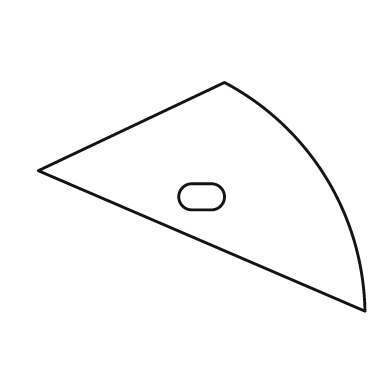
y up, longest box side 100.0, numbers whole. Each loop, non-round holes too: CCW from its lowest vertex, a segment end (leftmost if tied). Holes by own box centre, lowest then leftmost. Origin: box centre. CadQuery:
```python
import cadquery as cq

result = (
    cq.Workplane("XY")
    .moveTo(50.0, -35.0)
    .threePointArc((38.0, 6.0), (7.0, 35.0))
    .lineTo(-50.0, 8.0)
    .close()
    .moveTo(-3.0, -4.0)
    .lineTo(3.0, -4.0)
    .threePointArc((7.0, 0.0), (3.0, 4.0))
    .lineTo(-3.0, 4.0)
    .threePointArc((-7.0, 0.0), (-3.0, -4.0))
    .close()
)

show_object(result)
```